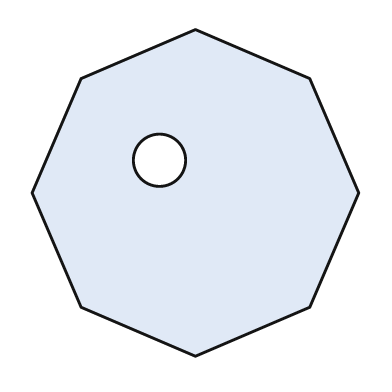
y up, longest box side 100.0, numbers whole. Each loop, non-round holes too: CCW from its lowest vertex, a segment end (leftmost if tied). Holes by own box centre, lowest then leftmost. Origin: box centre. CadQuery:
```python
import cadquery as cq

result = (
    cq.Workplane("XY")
    .moveTo(0.0, -50.0)
    .lineTo(35.0, -35.0)
    .lineTo(50.0, 0.0)
    .lineTo(35.0, 35.0)
    .lineTo(0.0, 50.0)
    .lineTo(-35.0, 35.0)
    .lineTo(-50.0, 0.0)
    .lineTo(-35.0, -35.0)
    .close()
    .moveTo(-11.0, 10.0)
    .circle(8.0)
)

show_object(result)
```